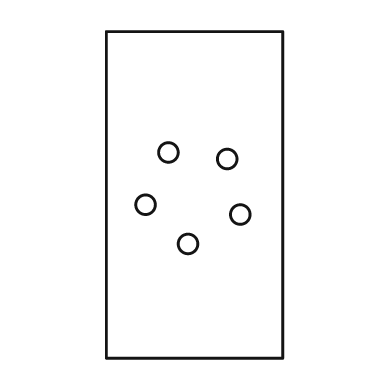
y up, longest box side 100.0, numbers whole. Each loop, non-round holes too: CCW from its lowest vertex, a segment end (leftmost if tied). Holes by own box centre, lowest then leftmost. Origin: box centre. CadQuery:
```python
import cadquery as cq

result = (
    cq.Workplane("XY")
    .moveTo(-27.0, -50.0)
    .lineTo(27.0, -50.0)
    .lineTo(27.0, 50.0)
    .lineTo(-27.0, 50.0)
    .close()
    .moveTo(-2.0, -15.0)
    .circle(3.0)
    .moveTo(14.0, -6.0)
    .circle(3.0)
    .moveTo(-15.0, -3.0)
    .circle(3.0)
    .moveTo(10.0, 11.0)
    .circle(3.0)
    .moveTo(-8.0, 13.0)
    .circle(3.0)
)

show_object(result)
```